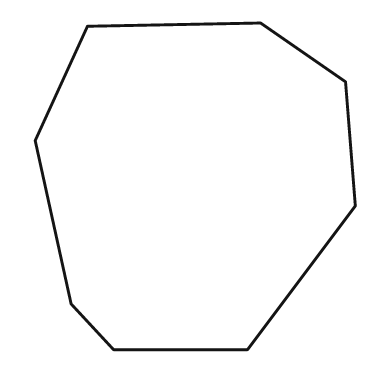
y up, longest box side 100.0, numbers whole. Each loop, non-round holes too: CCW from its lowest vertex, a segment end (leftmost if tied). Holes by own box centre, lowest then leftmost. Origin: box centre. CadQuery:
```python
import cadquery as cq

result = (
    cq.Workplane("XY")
    .moveTo(-25.0, -50.0)
    .lineTo(16.0, -50.0)
    .lineTo(49.0, -6.0)
    .lineTo(46.0, 32.0)
    .lineTo(20.0, 50.0)
    .lineTo(-33.0, 49.0)
    .lineTo(-49.0, 14.0)
    .lineTo(-38.0, -36.0)
    .close()
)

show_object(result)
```